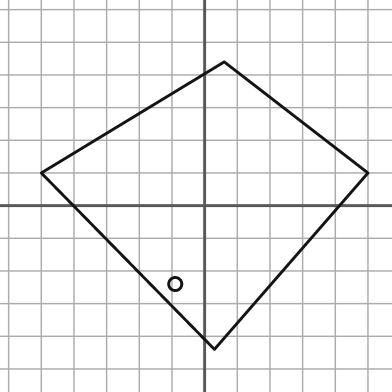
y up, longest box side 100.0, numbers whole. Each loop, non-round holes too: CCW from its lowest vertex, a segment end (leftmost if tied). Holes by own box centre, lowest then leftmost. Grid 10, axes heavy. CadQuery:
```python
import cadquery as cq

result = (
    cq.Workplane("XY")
    .moveTo(3.0, -44.0)
    .lineTo(50.0, 10.0)
    .lineTo(6.0, 44.0)
    .lineTo(-50.0, 10.0)
    .close()
    .moveTo(-9.0, -24.0)
    .circle(2.0)
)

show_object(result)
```